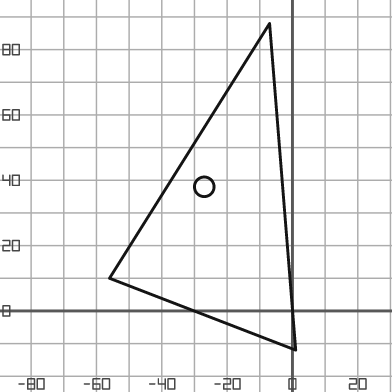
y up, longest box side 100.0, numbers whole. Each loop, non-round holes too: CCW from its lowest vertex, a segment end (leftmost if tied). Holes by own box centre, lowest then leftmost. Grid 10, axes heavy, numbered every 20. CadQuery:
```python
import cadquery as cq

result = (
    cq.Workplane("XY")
    .moveTo(1.0, -12.0)
    .lineTo(-7.0, 88.0)
    .lineTo(-56.0, 10.0)
    .close()
    .moveTo(-27.0, 38.0)
    .circle(3.0)
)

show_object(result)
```